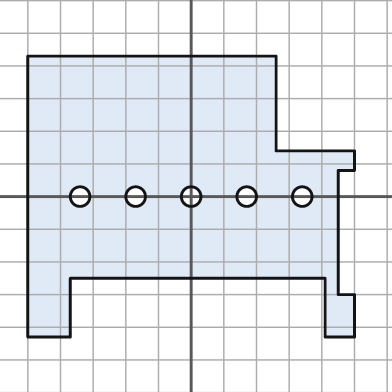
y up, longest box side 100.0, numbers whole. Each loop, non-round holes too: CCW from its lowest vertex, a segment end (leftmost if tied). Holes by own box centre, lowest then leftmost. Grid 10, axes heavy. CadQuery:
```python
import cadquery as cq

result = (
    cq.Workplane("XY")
    .moveTo(-50.0, -43.0)
    .lineTo(-37.0, -43.0)
    .lineTo(-37.0, -25.0)
    .lineTo(41.0, -25.0)
    .lineTo(41.0, -43.0)
    .lineTo(50.0, -43.0)
    .lineTo(50.0, -30.0)
    .lineTo(45.0, -30.0)
    .lineTo(45.0, 8.0)
    .lineTo(50.0, 8.0)
    .lineTo(50.0, 14.0)
    .lineTo(26.0, 14.0)
    .lineTo(26.0, 43.0)
    .lineTo(-50.0, 43.0)
    .close()
    .moveTo(-34.0, 0.0)
    .circle(3.0)
    .moveTo(-17.0, 0.0)
    .circle(3.0)
    .moveTo(0.0, 0.0)
    .circle(3.0)
    .moveTo(17.0, 0.0)
    .circle(3.0)
    .moveTo(34.0, 0.0)
    .circle(3.0)
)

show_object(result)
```